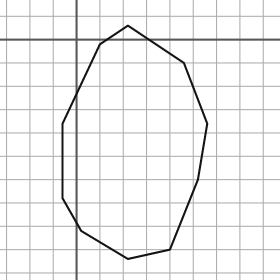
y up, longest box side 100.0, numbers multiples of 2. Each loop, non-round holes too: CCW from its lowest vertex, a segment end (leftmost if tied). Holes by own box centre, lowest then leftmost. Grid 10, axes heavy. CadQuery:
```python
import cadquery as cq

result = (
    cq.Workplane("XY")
    .moveTo(22.0, -94.0)
    .lineTo(40.0, -90.0)
    .lineTo(52.0, -60.0)
    .lineTo(56.0, -36.0)
    .lineTo(46.0, -10.0)
    .lineTo(22.0, 6.0)
    .lineTo(10.0, -2.0)
    .lineTo(-6.0, -36.0)
    .lineTo(-6.0, -68.0)
    .lineTo(2.0, -82.0)
    .close()
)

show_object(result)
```